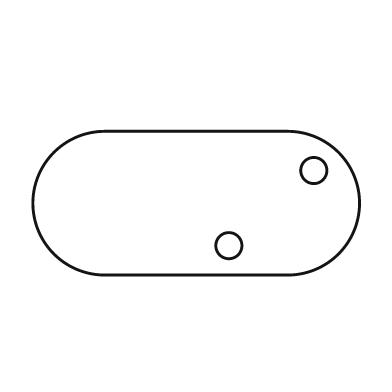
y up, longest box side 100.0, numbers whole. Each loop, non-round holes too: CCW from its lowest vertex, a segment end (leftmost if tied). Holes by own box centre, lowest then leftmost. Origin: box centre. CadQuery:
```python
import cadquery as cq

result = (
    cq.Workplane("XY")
    .moveTo(-28.0, -22.0)
    .lineTo(28.0, -22.0)
    .threePointArc((50.0, 0.0), (28.0, 22.0))
    .lineTo(-28.0, 22.0)
    .threePointArc((-50.0, 0.0), (-28.0, -22.0))
    .close()
    .moveTo(10.0, -13.0)
    .circle(4.0)
    .moveTo(36.0, 10.0)
    .circle(4.0)
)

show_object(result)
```